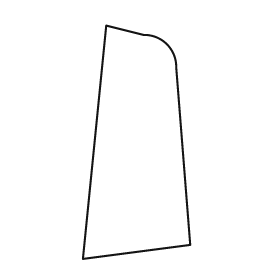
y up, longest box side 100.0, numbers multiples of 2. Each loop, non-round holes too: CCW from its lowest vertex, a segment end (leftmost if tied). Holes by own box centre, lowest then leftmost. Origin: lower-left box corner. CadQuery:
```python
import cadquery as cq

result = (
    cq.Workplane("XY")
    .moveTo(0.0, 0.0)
    .lineTo(46.0, 6.0)
    .lineTo(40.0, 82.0)
    .threePointArc((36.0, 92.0), (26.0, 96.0))
    .lineTo(10.0, 100.0)
    .close()
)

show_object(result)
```